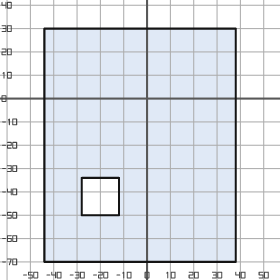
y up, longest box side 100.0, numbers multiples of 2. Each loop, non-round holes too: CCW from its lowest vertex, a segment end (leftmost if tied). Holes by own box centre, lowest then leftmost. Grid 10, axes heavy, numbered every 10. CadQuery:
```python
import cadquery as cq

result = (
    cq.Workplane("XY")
    .moveTo(-44.0, -70.0)
    .lineTo(38.0, -70.0)
    .lineTo(38.0, 30.0)
    .lineTo(-44.0, 30.0)
    .close()
    .moveTo(-28.0, -50.0)
    .lineTo(-12.0, -50.0)
    .lineTo(-12.0, -34.0)
    .lineTo(-28.0, -34.0)
    .close()
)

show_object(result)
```